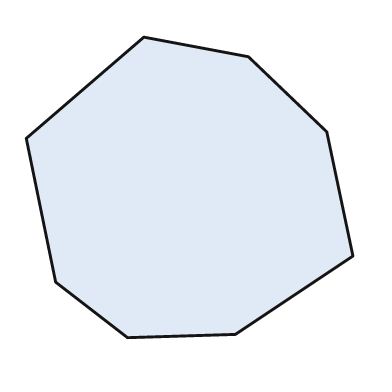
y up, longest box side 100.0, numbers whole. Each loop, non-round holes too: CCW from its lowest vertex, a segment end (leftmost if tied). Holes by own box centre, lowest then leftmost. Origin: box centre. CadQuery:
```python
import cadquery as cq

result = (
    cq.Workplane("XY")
    .moveTo(-19.0, -46.0)
    .lineTo(14.0, -45.0)
    .lineTo(50.0, -21.0)
    .lineTo(42.0, 17.0)
    .lineTo(18.0, 40.0)
    .lineTo(-14.0, 46.0)
    .lineTo(-50.0, 15.0)
    .lineTo(-41.0, -29.0)
    .close()
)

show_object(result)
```